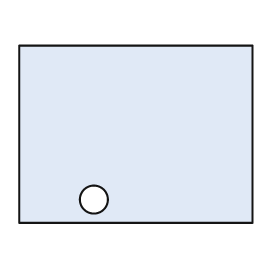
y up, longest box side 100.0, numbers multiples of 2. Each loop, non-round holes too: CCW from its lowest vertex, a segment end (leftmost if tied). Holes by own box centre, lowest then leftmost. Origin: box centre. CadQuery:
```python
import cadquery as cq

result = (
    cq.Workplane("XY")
    .moveTo(-50.0, -38.0)
    .lineTo(50.0, -38.0)
    .lineTo(50.0, 38.0)
    .lineTo(-50.0, 38.0)
    .close()
    .moveTo(-18.0, -28.0)
    .circle(6.0)
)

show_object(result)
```